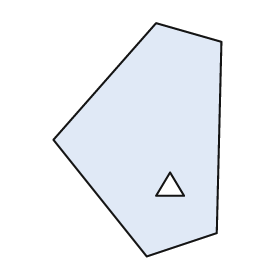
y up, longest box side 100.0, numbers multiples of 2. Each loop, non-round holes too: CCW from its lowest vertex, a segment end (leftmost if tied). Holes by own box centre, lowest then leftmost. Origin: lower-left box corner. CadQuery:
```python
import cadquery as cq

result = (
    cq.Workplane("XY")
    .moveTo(40.0, 0.0)
    .lineTo(70.0, 10.0)
    .lineTo(72.0, 92.0)
    .lineTo(44.0, 100.0)
    .lineTo(0.0, 50.0)
    .close()
    .moveTo(44.0, 26.0)
    .lineTo(56.0, 26.0)
    .lineTo(50.0, 36.0)
    .close()
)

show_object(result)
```